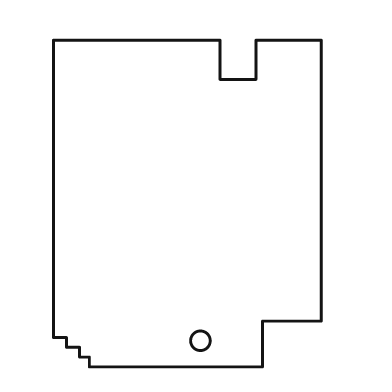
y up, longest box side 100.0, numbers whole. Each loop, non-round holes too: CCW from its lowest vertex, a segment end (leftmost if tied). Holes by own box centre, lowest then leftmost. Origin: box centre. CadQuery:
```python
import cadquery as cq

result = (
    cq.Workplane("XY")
    .moveTo(-30.0, -50.0)
    .lineTo(23.0, -50.0)
    .lineTo(23.0, -36.0)
    .lineTo(41.0, -36.0)
    .lineTo(41.0, 50.0)
    .lineTo(21.0, 50.0)
    .lineTo(21.0, 38.0)
    .lineTo(10.0, 38.0)
    .lineTo(10.0, 50.0)
    .lineTo(-41.0, 50.0)
    .lineTo(-41.0, -41.0)
    .lineTo(-37.0, -41.0)
    .lineTo(-37.0, -44.0)
    .lineTo(-33.0, -44.0)
    .lineTo(-33.0, -47.0)
    .lineTo(-30.0, -47.0)
    .close()
    .moveTo(4.0, -42.0)
    .circle(3.0)
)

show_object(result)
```